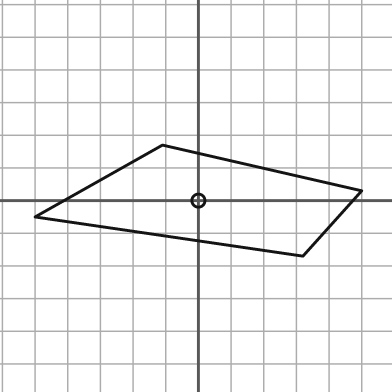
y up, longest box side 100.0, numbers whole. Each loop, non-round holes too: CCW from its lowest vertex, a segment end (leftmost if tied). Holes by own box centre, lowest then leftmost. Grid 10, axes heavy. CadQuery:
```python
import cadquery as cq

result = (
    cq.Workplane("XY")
    .moveTo(32.0, -17.0)
    .lineTo(50.0, 3.0)
    .lineTo(-11.0, 17.0)
    .lineTo(-50.0, -5.0)
    .close()
    .moveTo(0.0, 0.0)
    .circle(2.0)
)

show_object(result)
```